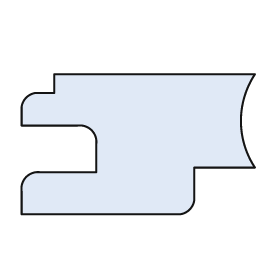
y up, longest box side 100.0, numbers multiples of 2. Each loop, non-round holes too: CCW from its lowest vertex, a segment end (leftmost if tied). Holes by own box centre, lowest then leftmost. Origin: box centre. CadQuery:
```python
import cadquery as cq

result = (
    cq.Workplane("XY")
    .moveTo(-50.0, -30.0)
    .lineTo(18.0, -30.0)
    .threePointArc((22.0, -28.0), (24.0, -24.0))
    .lineTo(24.0, -10.0)
    .lineTo(50.0, -10.0)
    .threePointArc((44.0, 10.0), (50.0, 30.0))
    .lineTo(-36.0, 30.0)
    .lineTo(-36.0, 22.0)
    .lineTo(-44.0, 22.0)
    .threePointArc((-48.0, 20.0), (-50.0, 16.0))
    .lineTo(-50.0, 8.0)
    .lineTo(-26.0, 8.0)
    .threePointArc((-20.0, 6.0), (-18.0, 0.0))
    .lineTo(-18.0, -12.0)
    .lineTo(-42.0, -12.0)
    .threePointArc((-48.0, -14.0), (-50.0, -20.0))
    .close()
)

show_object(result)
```